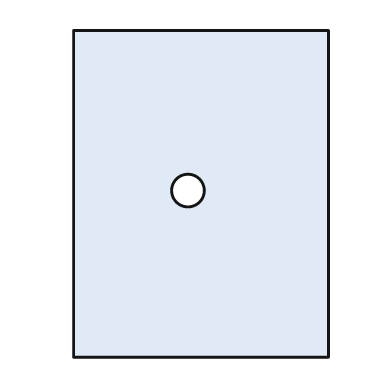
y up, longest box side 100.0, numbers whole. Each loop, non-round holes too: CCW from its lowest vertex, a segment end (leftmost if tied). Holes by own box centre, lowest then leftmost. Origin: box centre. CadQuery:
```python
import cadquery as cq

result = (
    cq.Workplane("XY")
    .moveTo(-39.0, -50.0)
    .lineTo(39.0, -50.0)
    .lineTo(39.0, 50.0)
    .lineTo(-39.0, 50.0)
    .close()
    .moveTo(-4.0, 1.0)
    .circle(5.0)
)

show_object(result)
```